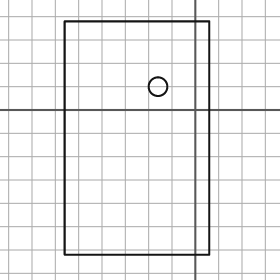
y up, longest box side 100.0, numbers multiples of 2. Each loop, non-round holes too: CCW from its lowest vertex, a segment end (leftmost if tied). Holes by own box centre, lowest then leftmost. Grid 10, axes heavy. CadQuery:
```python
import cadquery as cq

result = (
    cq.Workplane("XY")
    .moveTo(-56.0, -62.0)
    .lineTo(6.0, -62.0)
    .lineTo(6.0, 38.0)
    .lineTo(-56.0, 38.0)
    .close()
    .moveTo(-16.0, 10.0)
    .circle(4.0)
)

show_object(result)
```